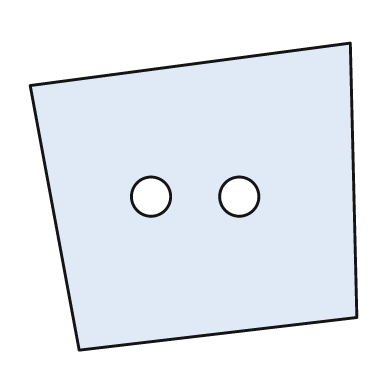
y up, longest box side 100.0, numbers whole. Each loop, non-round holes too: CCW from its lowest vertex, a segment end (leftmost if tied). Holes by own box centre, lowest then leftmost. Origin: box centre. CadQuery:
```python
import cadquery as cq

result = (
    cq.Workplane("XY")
    .moveTo(-35.0, -47.0)
    .lineTo(50.0, -37.0)
    .lineTo(48.0, 47.0)
    .lineTo(-50.0, 34.0)
    .close()
    .moveTo(-13.0, 0.0)
    .circle(6.0)
    .moveTo(14.0, 0.0)
    .circle(6.0)
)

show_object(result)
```